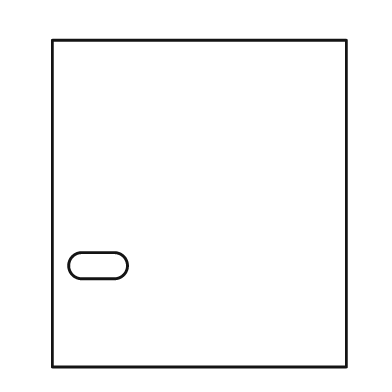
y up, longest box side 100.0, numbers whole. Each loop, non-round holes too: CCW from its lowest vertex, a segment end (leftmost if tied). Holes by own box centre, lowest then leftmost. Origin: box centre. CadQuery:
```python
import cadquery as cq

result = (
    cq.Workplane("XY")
    .moveTo(-45.0, -50.0)
    .lineTo(45.0, -50.0)
    .lineTo(45.0, 50.0)
    .lineTo(-45.0, 50.0)
    .close()
    .moveTo(-36.0, -23.0)
    .lineTo(-26.0, -23.0)
    .threePointArc((-22.0, -19.0), (-26.0, -15.0))
    .lineTo(-36.0, -15.0)
    .threePointArc((-40.0, -19.0), (-36.0, -23.0))
    .close()
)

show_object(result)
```